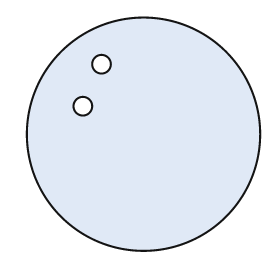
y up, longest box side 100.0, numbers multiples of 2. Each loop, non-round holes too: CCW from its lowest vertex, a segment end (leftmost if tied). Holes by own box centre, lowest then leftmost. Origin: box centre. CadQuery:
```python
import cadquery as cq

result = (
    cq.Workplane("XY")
    .moveTo(0.0, 0.0)
    .circle(50.0)
    .moveTo(-26.0, 12.0)
    .circle(4.0)
    .moveTo(-18.0, 30.0)
    .circle(4.0)
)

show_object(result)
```